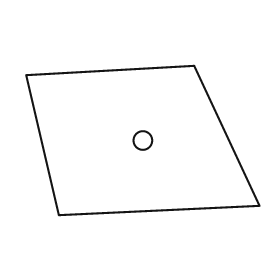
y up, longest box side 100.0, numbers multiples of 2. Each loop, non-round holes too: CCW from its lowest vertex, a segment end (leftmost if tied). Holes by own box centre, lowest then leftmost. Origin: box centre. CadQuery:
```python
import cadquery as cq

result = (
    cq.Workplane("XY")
    .moveTo(-36.0, -32.0)
    .lineTo(50.0, -28.0)
    .lineTo(22.0, 32.0)
    .lineTo(-50.0, 28.0)
    .close()
    .moveTo(0.0, 0.0)
    .circle(4.0)
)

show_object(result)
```